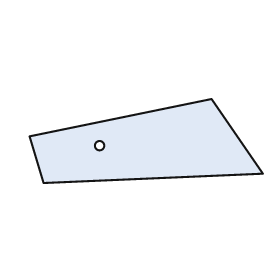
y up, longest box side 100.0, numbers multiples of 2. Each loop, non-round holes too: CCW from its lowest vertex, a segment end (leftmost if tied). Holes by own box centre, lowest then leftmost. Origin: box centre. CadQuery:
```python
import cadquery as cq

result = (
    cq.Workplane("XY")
    .moveTo(-44.0, -18.0)
    .lineTo(50.0, -14.0)
    .lineTo(28.0, 18.0)
    .lineTo(-50.0, 2.0)
    .close()
    .moveTo(-20.0, -2.0)
    .circle(2.0)
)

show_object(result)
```